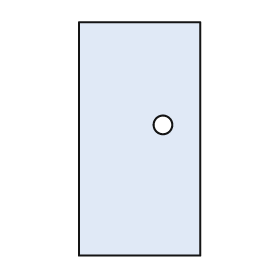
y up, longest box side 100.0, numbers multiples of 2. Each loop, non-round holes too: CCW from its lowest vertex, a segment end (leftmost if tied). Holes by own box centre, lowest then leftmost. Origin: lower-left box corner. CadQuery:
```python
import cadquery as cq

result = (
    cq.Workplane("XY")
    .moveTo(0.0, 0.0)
    .lineTo(52.0, 0.0)
    .lineTo(52.0, 100.0)
    .lineTo(0.0, 100.0)
    .close()
    .moveTo(36.0, 56.0)
    .circle(4.0)
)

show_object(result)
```